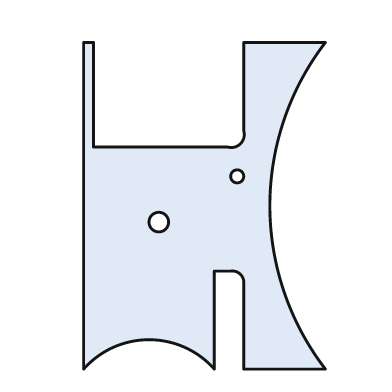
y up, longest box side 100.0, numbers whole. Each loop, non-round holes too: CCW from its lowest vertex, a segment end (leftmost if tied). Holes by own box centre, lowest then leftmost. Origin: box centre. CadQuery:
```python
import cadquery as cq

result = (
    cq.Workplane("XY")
    .moveTo(-37.0, -50.0)
    .threePointArc((-17.0, -41.0), (3.0, -50.0))
    .lineTo(3.0, -20.0)
    .lineTo(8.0, -20.0)
    .threePointArc((11.0, -21.0), (12.0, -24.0))
    .lineTo(12.0, -50.0)
    .lineTo(37.0, -50.0)
    .threePointArc((20.0, 0.0), (37.0, 50.0))
    .lineTo(12.0, 50.0)
    .lineTo(12.0, 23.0)
    .threePointArc((11.0, 19.0), (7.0, 18.0))
    .lineTo(-34.0, 18.0)
    .lineTo(-34.0, 50.0)
    .lineTo(-37.0, 50.0)
    .close()
    .moveTo(-14.0, -5.0)
    .circle(3.0)
    .moveTo(10.0, 9.0)
    .circle(2.0)
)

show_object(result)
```